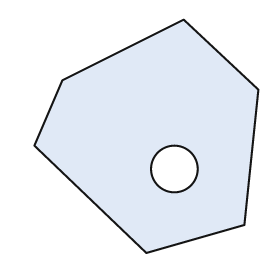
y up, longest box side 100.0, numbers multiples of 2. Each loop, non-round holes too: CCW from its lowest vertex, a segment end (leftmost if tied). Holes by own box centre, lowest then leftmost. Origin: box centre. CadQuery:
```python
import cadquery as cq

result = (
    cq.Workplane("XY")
    .moveTo(0.0, -50.0)
    .lineTo(42.0, -38.0)
    .lineTo(48.0, 20.0)
    .lineTo(16.0, 50.0)
    .lineTo(-36.0, 24.0)
    .lineTo(-48.0, -4.0)
    .close()
    .moveTo(12.0, -14.0)
    .circle(10.0)
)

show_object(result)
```